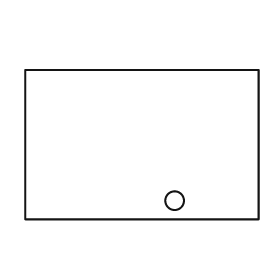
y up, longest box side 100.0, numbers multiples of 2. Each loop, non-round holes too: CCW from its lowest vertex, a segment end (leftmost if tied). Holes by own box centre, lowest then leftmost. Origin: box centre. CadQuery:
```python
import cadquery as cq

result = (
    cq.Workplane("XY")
    .moveTo(-50.0, -32.0)
    .lineTo(50.0, -32.0)
    .lineTo(50.0, 32.0)
    .lineTo(-50.0, 32.0)
    .close()
    .moveTo(14.0, -24.0)
    .circle(4.0)
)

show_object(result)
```